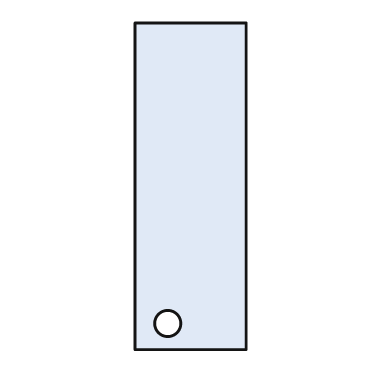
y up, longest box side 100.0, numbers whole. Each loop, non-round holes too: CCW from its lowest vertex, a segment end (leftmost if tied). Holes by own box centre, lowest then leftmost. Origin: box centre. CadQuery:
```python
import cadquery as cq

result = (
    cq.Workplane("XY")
    .moveTo(-17.0, -50.0)
    .lineTo(17.0, -50.0)
    .lineTo(17.0, 50.0)
    .lineTo(-17.0, 50.0)
    .close()
    .moveTo(-7.0, -42.0)
    .circle(4.0)
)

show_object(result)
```